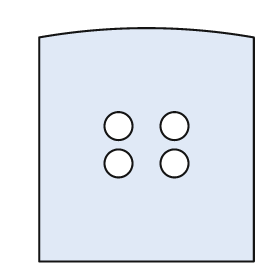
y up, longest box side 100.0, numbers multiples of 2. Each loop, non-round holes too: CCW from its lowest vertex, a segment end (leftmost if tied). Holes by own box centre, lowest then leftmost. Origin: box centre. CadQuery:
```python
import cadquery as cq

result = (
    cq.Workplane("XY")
    .moveTo(-46.0, -50.0)
    .lineTo(46.0, -50.0)
    .lineTo(46.0, 46.0)
    .threePointArc((0.0, 50.0), (-46.0, 46.0))
    .close()
    .moveTo(-12.0, -8.0)
    .circle(6.0)
    .moveTo(12.0, -8.0)
    .circle(6.0)
    .moveTo(-12.0, 8.0)
    .circle(6.0)
    .moveTo(12.0, 8.0)
    .circle(6.0)
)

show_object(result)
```